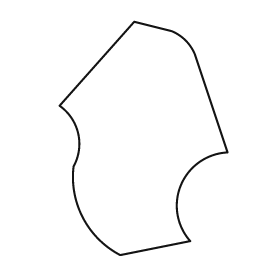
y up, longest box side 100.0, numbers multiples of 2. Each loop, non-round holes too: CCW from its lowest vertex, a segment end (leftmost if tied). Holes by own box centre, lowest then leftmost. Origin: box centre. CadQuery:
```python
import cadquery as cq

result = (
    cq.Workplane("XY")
    .moveTo(-10.0, -50.0)
    .lineTo(20.0, -44.0)
    .threePointArc((16.0, -20.0), (36.0, -6.0))
    .lineTo(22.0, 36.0)
    .threePointArc((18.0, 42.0), (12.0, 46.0))
    .lineTo(-4.0, 50.0)
    .lineTo(-36.0, 14.0)
    .threePointArc((-28.0, 2.0), (-30.0, -12.0))
    .threePointArc((-26.0, -34.0), (-10.0, -50.0))
    .close()
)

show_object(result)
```